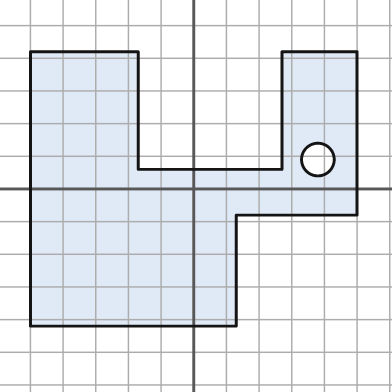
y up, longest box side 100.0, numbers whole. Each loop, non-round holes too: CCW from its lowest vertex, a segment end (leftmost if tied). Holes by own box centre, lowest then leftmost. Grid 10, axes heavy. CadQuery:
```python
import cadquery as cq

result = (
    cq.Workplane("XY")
    .moveTo(-50.0, -42.0)
    .lineTo(13.0, -42.0)
    .lineTo(13.0, -8.0)
    .lineTo(50.0, -8.0)
    .lineTo(50.0, 42.0)
    .lineTo(27.0, 42.0)
    .lineTo(27.0, 6.0)
    .lineTo(-17.0, 6.0)
    .lineTo(-17.0, 42.0)
    .lineTo(-50.0, 42.0)
    .close()
    .moveTo(38.0, 9.0)
    .circle(5.0)
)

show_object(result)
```